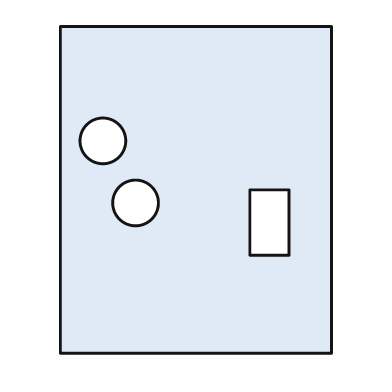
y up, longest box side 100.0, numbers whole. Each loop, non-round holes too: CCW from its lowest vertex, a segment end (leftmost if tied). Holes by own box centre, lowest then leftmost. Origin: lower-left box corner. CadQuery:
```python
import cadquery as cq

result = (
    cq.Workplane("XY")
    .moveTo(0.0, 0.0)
    .lineTo(83.0, 0.0)
    .lineTo(83.0, 100.0)
    .lineTo(0.0, 100.0)
    .close()
    .moveTo(58.0, 30.0)
    .lineTo(70.0, 30.0)
    .lineTo(70.0, 50.0)
    .lineTo(58.0, 50.0)
    .close()
    .moveTo(23.0, 46.0)
    .circle(7.0)
    .moveTo(13.0, 65.0)
    .circle(7.0)
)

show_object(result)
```